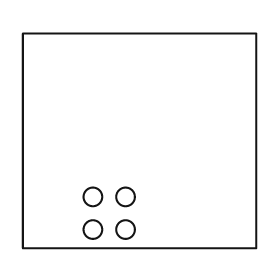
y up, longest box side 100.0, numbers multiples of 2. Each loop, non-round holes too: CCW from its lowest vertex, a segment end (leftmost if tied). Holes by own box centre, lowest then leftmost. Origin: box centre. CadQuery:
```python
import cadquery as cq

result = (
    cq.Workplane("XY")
    .moveTo(-50.0, -46.0)
    .lineTo(50.0, -46.0)
    .lineTo(50.0, 46.0)
    .lineTo(-50.0, 46.0)
    .close()
    .moveTo(-20.0, -38.0)
    .circle(4.0)
    .moveTo(-6.0, -38.0)
    .circle(4.0)
    .moveTo(-20.0, -24.0)
    .circle(4.0)
    .moveTo(-6.0, -24.0)
    .circle(4.0)
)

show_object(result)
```